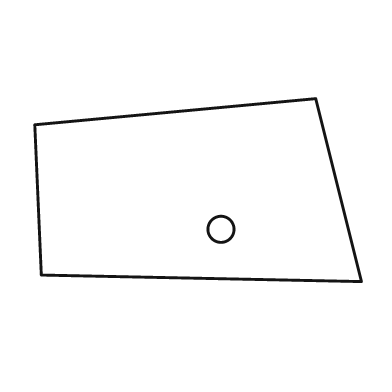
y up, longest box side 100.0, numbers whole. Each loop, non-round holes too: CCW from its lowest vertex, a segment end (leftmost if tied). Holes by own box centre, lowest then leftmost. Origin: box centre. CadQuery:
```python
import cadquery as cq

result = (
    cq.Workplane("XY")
    .moveTo(50.0, -28.0)
    .lineTo(36.0, 28.0)
    .lineTo(-50.0, 20.0)
    .lineTo(-48.0, -26.0)
    .close()
    .moveTo(7.0, -12.0)
    .circle(4.0)
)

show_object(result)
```